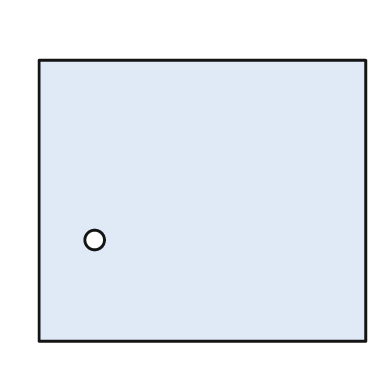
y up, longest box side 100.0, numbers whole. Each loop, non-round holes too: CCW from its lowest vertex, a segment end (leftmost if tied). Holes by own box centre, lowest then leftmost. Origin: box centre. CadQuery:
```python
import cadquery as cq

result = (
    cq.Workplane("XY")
    .moveTo(-50.0, -43.0)
    .lineTo(50.0, -43.0)
    .lineTo(50.0, 43.0)
    .lineTo(-50.0, 43.0)
    .close()
    .moveTo(-33.0, -12.0)
    .circle(3.0)
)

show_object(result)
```